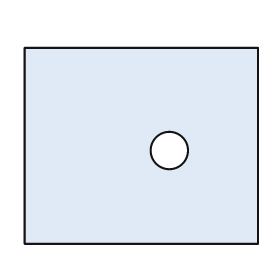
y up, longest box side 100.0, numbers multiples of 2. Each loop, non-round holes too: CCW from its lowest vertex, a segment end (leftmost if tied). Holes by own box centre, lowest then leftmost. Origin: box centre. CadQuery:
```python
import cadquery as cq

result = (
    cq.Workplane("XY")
    .moveTo(-50.0, -42.0)
    .lineTo(50.0, -42.0)
    .lineTo(50.0, 42.0)
    .lineTo(-50.0, 42.0)
    .close()
    .moveTo(12.0, -2.0)
    .circle(8.0)
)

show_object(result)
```